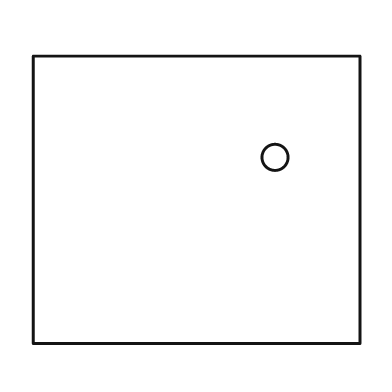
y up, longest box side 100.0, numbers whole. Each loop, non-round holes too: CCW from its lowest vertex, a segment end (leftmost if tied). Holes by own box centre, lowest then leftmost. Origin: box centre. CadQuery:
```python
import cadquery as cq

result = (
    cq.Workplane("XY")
    .moveTo(-50.0, -44.0)
    .lineTo(50.0, -44.0)
    .lineTo(50.0, 44.0)
    .lineTo(-50.0, 44.0)
    .close()
    .moveTo(24.0, 13.0)
    .circle(4.0)
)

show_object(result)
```